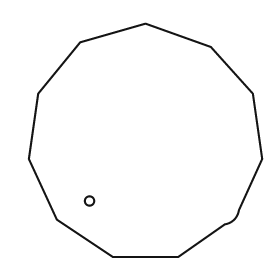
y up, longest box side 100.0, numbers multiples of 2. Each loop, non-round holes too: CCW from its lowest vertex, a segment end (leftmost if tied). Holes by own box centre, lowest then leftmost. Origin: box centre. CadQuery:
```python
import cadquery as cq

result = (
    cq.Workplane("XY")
    .moveTo(-14.0, -50.0)
    .lineTo(14.0, -50.0)
    .lineTo(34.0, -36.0)
    .threePointArc((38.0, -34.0), (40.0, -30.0))
    .lineTo(50.0, -8.0)
    .lineTo(46.0, 20.0)
    .lineTo(28.0, 40.0)
    .lineTo(0.0, 50.0)
    .lineTo(-28.0, 42.0)
    .lineTo(-46.0, 20.0)
    .lineTo(-50.0, -8.0)
    .lineTo(-38.0, -34.0)
    .close()
    .moveTo(-24.0, -26.0)
    .circle(2.0)
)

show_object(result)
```